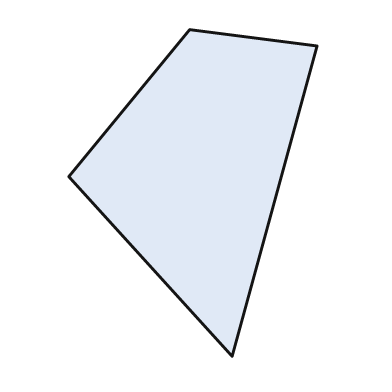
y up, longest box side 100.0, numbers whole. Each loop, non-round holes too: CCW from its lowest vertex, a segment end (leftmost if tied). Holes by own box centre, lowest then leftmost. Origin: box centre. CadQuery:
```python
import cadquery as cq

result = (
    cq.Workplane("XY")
    .moveTo(12.0, -50.0)
    .lineTo(38.0, 45.0)
    .lineTo(-1.0, 50.0)
    .lineTo(-38.0, 5.0)
    .close()
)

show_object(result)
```